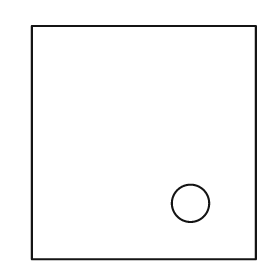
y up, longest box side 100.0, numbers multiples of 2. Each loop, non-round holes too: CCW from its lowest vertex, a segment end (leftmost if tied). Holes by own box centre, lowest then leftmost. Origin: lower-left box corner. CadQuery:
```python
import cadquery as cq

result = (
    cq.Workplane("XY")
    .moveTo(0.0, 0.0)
    .lineTo(96.0, 0.0)
    .lineTo(96.0, 100.0)
    .lineTo(0.0, 100.0)
    .close()
    .moveTo(68.0, 24.0)
    .circle(8.0)
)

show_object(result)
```